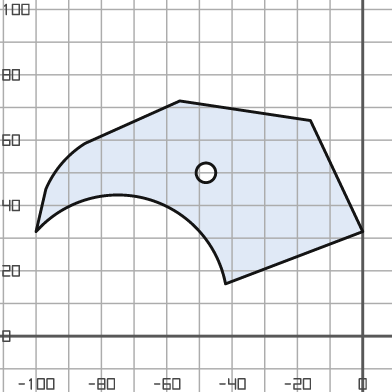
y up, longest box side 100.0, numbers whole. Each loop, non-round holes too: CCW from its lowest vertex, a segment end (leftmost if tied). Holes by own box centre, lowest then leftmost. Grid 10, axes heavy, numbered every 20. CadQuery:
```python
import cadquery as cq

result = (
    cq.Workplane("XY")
    .moveTo(-42.0, 16.0)
    .lineTo(0.0, 32.0)
    .lineTo(-16.0, 66.0)
    .lineTo(-56.0, 72.0)
    .lineTo(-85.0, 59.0)
    .threePointArc((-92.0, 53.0), (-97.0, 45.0))
    .lineTo(-100.0, 32.0)
    .threePointArc((-66.0, 42.0), (-42.0, 16.0))
    .close()
    .moveTo(-48.0, 50.0)
    .circle(3.0)
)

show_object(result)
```